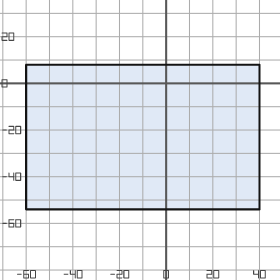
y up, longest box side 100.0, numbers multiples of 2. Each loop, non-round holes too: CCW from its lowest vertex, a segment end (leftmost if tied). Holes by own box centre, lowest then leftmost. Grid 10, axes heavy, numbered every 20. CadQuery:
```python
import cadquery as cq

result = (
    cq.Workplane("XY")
    .moveTo(-60.0, -54.0)
    .lineTo(40.0, -54.0)
    .lineTo(40.0, 8.0)
    .lineTo(-60.0, 8.0)
    .close()
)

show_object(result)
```